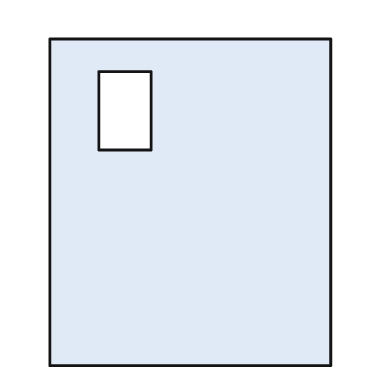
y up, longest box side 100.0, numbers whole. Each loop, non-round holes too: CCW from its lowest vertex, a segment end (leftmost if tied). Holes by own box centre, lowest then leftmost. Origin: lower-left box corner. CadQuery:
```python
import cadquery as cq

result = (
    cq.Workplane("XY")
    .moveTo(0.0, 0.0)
    .lineTo(86.0, 0.0)
    .lineTo(86.0, 100.0)
    .lineTo(0.0, 100.0)
    .close()
    .moveTo(15.0, 66.0)
    .lineTo(31.0, 66.0)
    .lineTo(31.0, 90.0)
    .lineTo(15.0, 90.0)
    .close()
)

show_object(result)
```